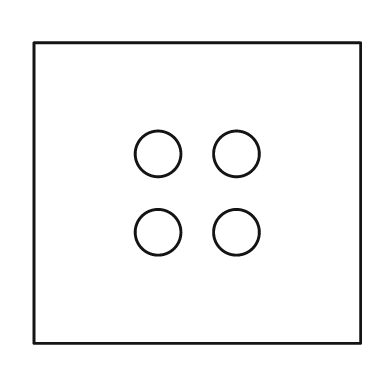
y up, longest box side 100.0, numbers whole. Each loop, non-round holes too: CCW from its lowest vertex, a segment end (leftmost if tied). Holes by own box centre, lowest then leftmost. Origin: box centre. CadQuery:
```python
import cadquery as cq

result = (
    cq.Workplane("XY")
    .moveTo(-50.0, -46.0)
    .lineTo(50.0, -46.0)
    .lineTo(50.0, 46.0)
    .lineTo(-50.0, 46.0)
    .close()
    .moveTo(-12.0, -12.0)
    .circle(7.0)
    .moveTo(12.0, -12.0)
    .circle(7.0)
    .moveTo(-12.0, 12.0)
    .circle(7.0)
    .moveTo(12.0, 12.0)
    .circle(7.0)
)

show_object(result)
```